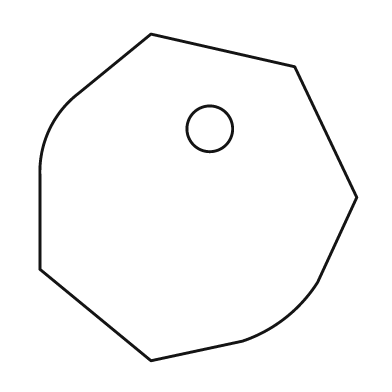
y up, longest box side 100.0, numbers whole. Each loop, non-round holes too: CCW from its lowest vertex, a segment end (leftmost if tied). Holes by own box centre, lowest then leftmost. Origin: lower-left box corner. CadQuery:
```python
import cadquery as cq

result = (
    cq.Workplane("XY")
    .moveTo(34.0, 0.0)
    .lineTo(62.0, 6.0)
    .threePointArc((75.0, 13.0), (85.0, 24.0))
    .lineTo(97.0, 50.0)
    .lineTo(78.0, 90.0)
    .lineTo(34.0, 100.0)
    .lineTo(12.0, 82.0)
    .threePointArc((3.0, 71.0), (0.0, 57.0))
    .lineTo(0.0, 28.0)
    .close()
    .moveTo(52.0, 71.0)
    .circle(7.0)
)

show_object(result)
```